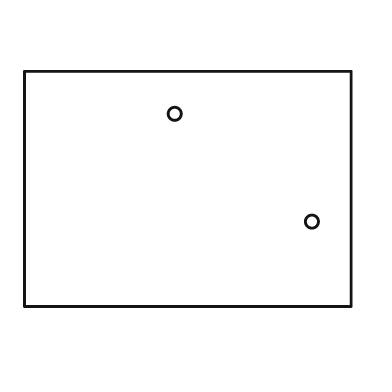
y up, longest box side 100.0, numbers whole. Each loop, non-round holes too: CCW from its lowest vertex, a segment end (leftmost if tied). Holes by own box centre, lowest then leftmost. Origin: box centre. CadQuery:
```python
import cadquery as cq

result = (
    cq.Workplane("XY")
    .moveTo(-50.0, -36.0)
    .lineTo(50.0, -36.0)
    .lineTo(50.0, 36.0)
    .lineTo(-50.0, 36.0)
    .close()
    .moveTo(38.0, -10.0)
    .circle(2.0)
    .moveTo(-4.0, 23.0)
    .circle(2.0)
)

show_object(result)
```